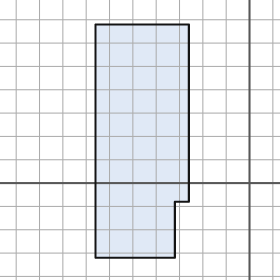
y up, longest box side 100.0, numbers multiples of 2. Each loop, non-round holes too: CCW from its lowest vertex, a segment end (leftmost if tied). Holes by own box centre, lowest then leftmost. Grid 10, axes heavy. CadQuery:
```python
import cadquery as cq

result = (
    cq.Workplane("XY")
    .moveTo(-66.0, -32.0)
    .lineTo(-32.0, -32.0)
    .lineTo(-32.0, -8.0)
    .lineTo(-26.0, -8.0)
    .lineTo(-26.0, 68.0)
    .lineTo(-66.0, 68.0)
    .close()
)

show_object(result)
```